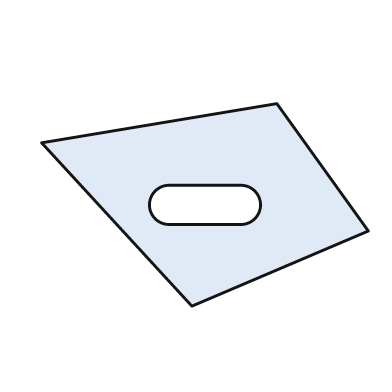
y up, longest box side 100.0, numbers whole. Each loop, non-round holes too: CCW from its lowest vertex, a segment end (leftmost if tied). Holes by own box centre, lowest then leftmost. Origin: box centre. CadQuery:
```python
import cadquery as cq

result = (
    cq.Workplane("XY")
    .moveTo(-4.0, -31.0)
    .lineTo(50.0, -8.0)
    .lineTo(22.0, 31.0)
    .lineTo(-50.0, 19.0)
    .close()
    .moveTo(-11.0, -6.0)
    .lineTo(11.0, -6.0)
    .threePointArc((17.0, 0.0), (11.0, 6.0))
    .lineTo(-11.0, 6.0)
    .threePointArc((-17.0, 0.0), (-11.0, -6.0))
    .close()
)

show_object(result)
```